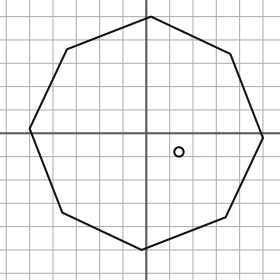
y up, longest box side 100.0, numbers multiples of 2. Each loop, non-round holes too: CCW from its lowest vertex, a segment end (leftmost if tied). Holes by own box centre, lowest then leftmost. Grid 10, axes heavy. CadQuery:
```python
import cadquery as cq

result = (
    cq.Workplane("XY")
    .moveTo(-2.0, -50.0)
    .lineTo(34.0, -36.0)
    .lineTo(50.0, -2.0)
    .lineTo(36.0, 34.0)
    .lineTo(2.0, 50.0)
    .lineTo(-34.0, 36.0)
    .lineTo(-50.0, 2.0)
    .lineTo(-36.0, -34.0)
    .close()
    .moveTo(14.0, -8.0)
    .circle(2.0)
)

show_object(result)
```